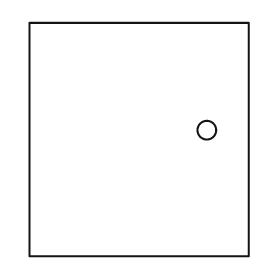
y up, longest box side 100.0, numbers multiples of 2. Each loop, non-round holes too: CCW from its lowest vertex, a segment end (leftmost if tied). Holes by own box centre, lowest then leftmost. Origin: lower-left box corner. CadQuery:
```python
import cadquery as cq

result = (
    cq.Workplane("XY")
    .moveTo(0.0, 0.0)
    .lineTo(94.0, 0.0)
    .lineTo(94.0, 100.0)
    .lineTo(0.0, 100.0)
    .close()
    .moveTo(76.0, 54.0)
    .circle(4.0)
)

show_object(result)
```